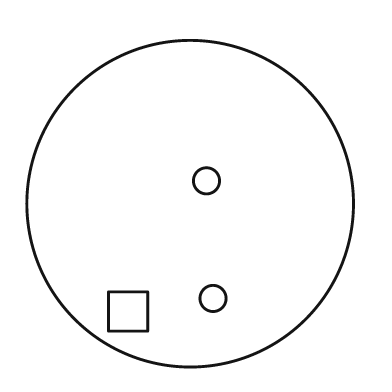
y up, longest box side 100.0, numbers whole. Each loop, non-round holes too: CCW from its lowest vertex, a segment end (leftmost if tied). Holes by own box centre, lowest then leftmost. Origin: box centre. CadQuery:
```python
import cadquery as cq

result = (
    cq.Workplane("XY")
    .moveTo(0.0, 0.0)
    .circle(50.0)
    .moveTo(-25.0, -39.0)
    .lineTo(-13.0, -39.0)
    .lineTo(-13.0, -27.0)
    .lineTo(-25.0, -27.0)
    .close()
    .moveTo(7.0, -29.0)
    .circle(4.0)
    .moveTo(5.0, 7.0)
    .circle(4.0)
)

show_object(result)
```